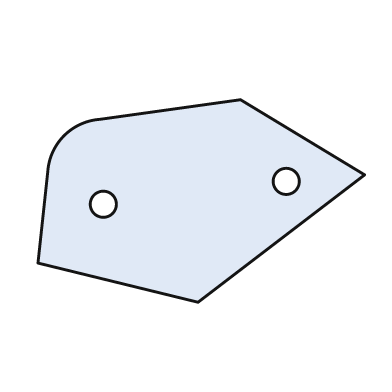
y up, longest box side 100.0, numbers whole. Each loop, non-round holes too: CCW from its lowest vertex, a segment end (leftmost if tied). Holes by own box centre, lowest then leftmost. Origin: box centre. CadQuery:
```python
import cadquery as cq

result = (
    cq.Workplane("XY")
    .moveTo(-1.0, -31.0)
    .lineTo(50.0, 8.0)
    .lineTo(12.0, 31.0)
    .lineTo(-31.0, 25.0)
    .threePointArc((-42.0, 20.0), (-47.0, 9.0))
    .lineTo(-50.0, -19.0)
    .close()
    .moveTo(-30.0, -1.0)
    .circle(4.0)
    .moveTo(26.0, 6.0)
    .circle(4.0)
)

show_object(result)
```